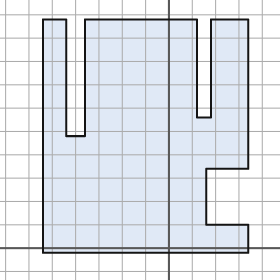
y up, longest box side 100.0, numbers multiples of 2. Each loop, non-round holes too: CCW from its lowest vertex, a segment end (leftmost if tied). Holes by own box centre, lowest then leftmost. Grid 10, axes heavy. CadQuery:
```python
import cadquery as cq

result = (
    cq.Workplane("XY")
    .moveTo(-54.0, -2.0)
    .lineTo(34.0, -2.0)
    .lineTo(34.0, 10.0)
    .lineTo(16.0, 10.0)
    .lineTo(16.0, 34.0)
    .lineTo(34.0, 34.0)
    .lineTo(34.0, 98.0)
    .lineTo(18.0, 98.0)
    .lineTo(18.0, 56.0)
    .lineTo(12.0, 56.0)
    .lineTo(12.0, 98.0)
    .lineTo(-36.0, 98.0)
    .lineTo(-36.0, 48.0)
    .lineTo(-44.0, 48.0)
    .lineTo(-44.0, 98.0)
    .lineTo(-54.0, 98.0)
    .close()
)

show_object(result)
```